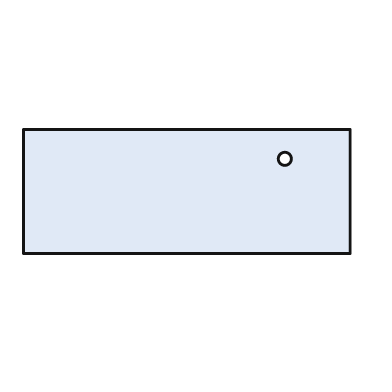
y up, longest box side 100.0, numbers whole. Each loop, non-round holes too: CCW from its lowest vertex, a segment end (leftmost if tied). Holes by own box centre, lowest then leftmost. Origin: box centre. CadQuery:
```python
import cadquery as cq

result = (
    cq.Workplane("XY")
    .moveTo(-50.0, -19.0)
    .lineTo(50.0, -19.0)
    .lineTo(50.0, 19.0)
    .lineTo(-50.0, 19.0)
    .close()
    .moveTo(30.0, 10.0)
    .circle(2.0)
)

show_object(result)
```